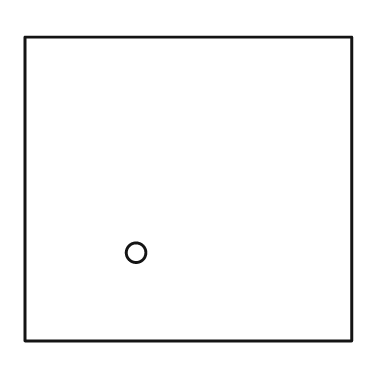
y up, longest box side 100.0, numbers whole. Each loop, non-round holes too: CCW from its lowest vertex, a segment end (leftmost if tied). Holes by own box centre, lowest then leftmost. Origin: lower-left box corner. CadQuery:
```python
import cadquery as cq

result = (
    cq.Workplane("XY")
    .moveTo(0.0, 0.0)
    .lineTo(100.0, 0.0)
    .lineTo(100.0, 93.0)
    .lineTo(0.0, 93.0)
    .close()
    .moveTo(34.0, 27.0)
    .circle(3.0)
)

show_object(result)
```